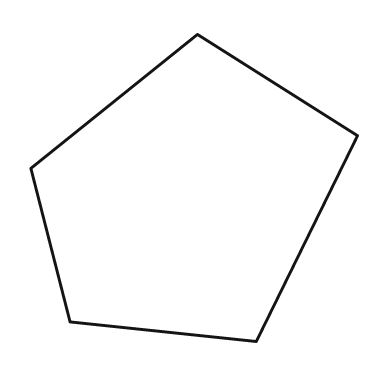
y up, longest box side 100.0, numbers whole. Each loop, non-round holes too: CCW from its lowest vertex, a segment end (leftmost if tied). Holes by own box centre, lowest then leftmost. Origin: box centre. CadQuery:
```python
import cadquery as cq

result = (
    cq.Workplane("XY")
    .moveTo(19.0, -47.0)
    .lineTo(50.0, 16.0)
    .lineTo(1.0, 47.0)
    .lineTo(-50.0, 6.0)
    .lineTo(-38.0, -41.0)
    .close()
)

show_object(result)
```